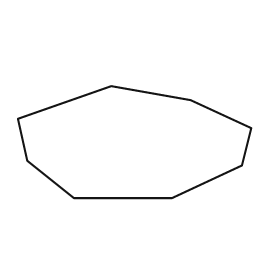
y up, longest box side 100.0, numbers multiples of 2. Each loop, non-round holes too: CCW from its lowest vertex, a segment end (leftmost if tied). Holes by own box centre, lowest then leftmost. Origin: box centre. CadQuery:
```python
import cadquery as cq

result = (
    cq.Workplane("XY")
    .moveTo(-26.0, -24.0)
    .lineTo(16.0, -24.0)
    .lineTo(46.0, -10.0)
    .lineTo(50.0, 6.0)
    .lineTo(24.0, 18.0)
    .lineTo(-10.0, 24.0)
    .lineTo(-50.0, 10.0)
    .lineTo(-46.0, -8.0)
    .close()
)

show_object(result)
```